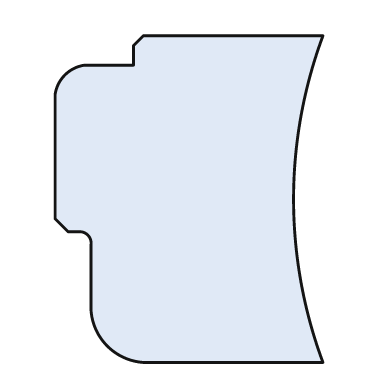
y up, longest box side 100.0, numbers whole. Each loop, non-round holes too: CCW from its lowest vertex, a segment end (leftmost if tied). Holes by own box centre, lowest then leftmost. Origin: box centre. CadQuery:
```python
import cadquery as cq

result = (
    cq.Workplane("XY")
    .moveTo(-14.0, -50.0)
    .lineTo(41.0, -50.0)
    .threePointArc((32.0, 0.0), (41.0, 50.0))
    .lineTo(-14.0, 50.0)
    .lineTo(-17.0, 47.0)
    .lineTo(-17.0, 41.0)
    .lineTo(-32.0, 41.0)
    .threePointArc((-38.0, 38.0), (-41.0, 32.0))
    .lineTo(-41.0, -6.0)
    .lineTo(-37.0, -10.0)
    .lineTo(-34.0, -10.0)
    .threePointArc((-31.0, -11.0), (-30.0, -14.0))
    .lineTo(-30.0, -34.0)
    .threePointArc((-25.0, -45.0), (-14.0, -50.0))
    .close()
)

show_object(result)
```